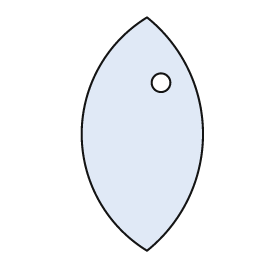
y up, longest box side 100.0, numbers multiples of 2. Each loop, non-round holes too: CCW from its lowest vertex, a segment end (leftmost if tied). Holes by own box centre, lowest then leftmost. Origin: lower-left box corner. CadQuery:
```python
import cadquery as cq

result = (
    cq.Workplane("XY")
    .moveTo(28.0, 0.0)
    .threePointArc((52.0, 50.0), (28.0, 100.0))
    .threePointArc((0.0, 50.0), (28.0, 0.0))
    .close()
    .moveTo(34.0, 72.0)
    .circle(4.0)
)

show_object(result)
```